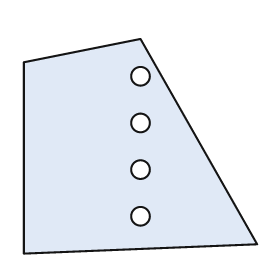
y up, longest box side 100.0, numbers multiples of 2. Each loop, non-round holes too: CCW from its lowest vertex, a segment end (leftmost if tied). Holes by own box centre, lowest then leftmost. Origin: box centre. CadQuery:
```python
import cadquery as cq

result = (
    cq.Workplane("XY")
    .moveTo(-50.0, -46.0)
    .lineTo(50.0, -42.0)
    .lineTo(0.0, 46.0)
    .lineTo(-50.0, 36.0)
    .close()
    .moveTo(0.0, -30.0)
    .circle(4.0)
    .moveTo(0.0, -10.0)
    .circle(4.0)
    .moveTo(0.0, 10.0)
    .circle(4.0)
    .moveTo(0.0, 30.0)
    .circle(4.0)
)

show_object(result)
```